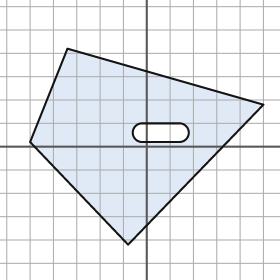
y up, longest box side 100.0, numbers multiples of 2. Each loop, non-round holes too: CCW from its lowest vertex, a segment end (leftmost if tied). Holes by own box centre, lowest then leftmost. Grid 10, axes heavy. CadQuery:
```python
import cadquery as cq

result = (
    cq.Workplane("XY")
    .moveTo(-8.0, -42.0)
    .lineTo(50.0, 18.0)
    .lineTo(-34.0, 42.0)
    .lineTo(-50.0, 2.0)
    .close()
    .moveTo(-2.0, 2.0)
    .lineTo(14.0, 2.0)
    .threePointArc((18.0, 6.0), (14.0, 10.0))
    .lineTo(-2.0, 10.0)
    .threePointArc((-6.0, 6.0), (-2.0, 2.0))
    .close()
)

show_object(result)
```